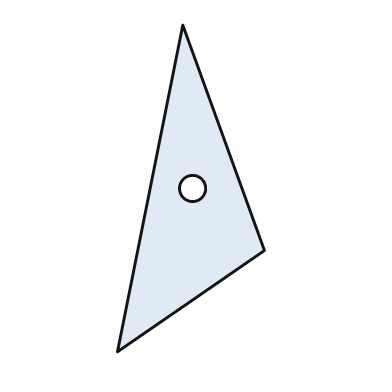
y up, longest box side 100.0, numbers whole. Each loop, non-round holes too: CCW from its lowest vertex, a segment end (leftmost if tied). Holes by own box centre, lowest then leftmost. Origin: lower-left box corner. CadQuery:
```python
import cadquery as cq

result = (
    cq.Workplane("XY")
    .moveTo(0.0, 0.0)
    .lineTo(45.0, 31.0)
    .lineTo(20.0, 100.0)
    .close()
    .moveTo(23.0, 50.0)
    .circle(4.0)
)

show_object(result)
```